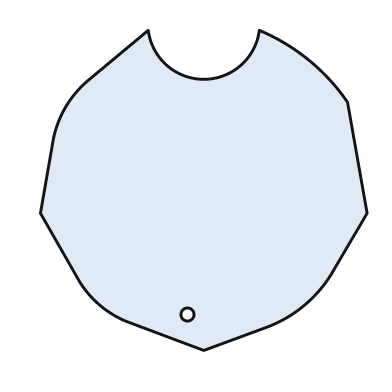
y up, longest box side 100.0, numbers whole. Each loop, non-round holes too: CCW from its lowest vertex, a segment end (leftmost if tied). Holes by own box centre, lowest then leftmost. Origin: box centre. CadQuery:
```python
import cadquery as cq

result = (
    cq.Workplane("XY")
    .moveTo(0.0, -49.0)
    .lineTo(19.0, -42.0)
    .threePointArc((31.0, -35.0), (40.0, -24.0))
    .lineTo(50.0, -7.0)
    .lineTo(44.0, 27.0)
    .threePointArc((32.0, 40.0), (17.0, 49.0))
    .threePointArc((0.0, 34.0), (-17.0, 49.0))
    .lineTo(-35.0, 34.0)
    .threePointArc((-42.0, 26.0), (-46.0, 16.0))
    .lineTo(-50.0, -7.0)
    .lineTo(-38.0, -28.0)
    .threePointArc((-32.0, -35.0), (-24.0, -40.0))
    .close()
    .moveTo(-5.0, -38.0)
    .circle(2.0)
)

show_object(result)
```